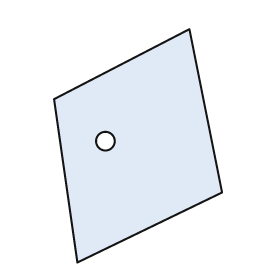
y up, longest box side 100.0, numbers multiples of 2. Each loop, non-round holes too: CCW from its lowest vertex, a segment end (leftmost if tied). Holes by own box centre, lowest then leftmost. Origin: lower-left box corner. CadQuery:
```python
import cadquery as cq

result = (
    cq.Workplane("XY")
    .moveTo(10.0, 0.0)
    .lineTo(72.0, 30.0)
    .lineTo(58.0, 100.0)
    .lineTo(0.0, 70.0)
    .close()
    .moveTo(22.0, 52.0)
    .circle(4.0)
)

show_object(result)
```